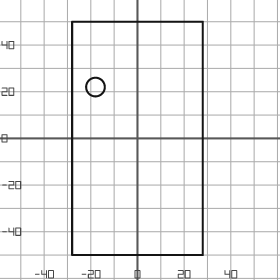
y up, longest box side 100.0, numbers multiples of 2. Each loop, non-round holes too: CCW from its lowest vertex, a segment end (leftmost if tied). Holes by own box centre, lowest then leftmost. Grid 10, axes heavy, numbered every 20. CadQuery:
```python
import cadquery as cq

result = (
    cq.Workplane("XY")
    .moveTo(-28.0, -50.0)
    .lineTo(28.0, -50.0)
    .lineTo(28.0, 50.0)
    .lineTo(-28.0, 50.0)
    .close()
    .moveTo(-18.0, 22.0)
    .circle(4.0)
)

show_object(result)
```